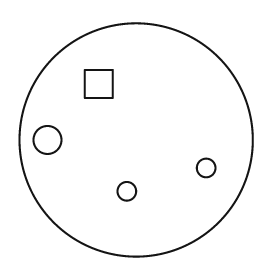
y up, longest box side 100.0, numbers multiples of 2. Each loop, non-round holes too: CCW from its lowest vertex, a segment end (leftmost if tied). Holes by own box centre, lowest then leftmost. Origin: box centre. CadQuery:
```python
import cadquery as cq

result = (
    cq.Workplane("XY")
    .moveTo(0.0, 0.0)
    .circle(50.0)
    .moveTo(-4.0, -22.0)
    .circle(4.0)
    .moveTo(30.0, -12.0)
    .circle(4.0)
    .moveTo(-38.0, 0.0)
    .circle(6.0)
    .moveTo(-22.0, 18.0)
    .lineTo(-10.0, 18.0)
    .lineTo(-10.0, 30.0)
    .lineTo(-22.0, 30.0)
    .close()
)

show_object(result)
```